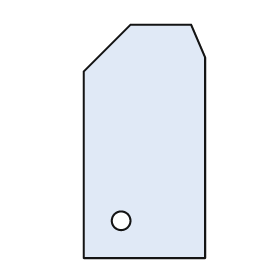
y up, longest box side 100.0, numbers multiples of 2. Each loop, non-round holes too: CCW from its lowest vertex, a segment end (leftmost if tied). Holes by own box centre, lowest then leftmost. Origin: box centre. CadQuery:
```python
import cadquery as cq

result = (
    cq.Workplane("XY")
    .moveTo(-26.0, -50.0)
    .lineTo(26.0, -50.0)
    .lineTo(26.0, 36.0)
    .lineTo(20.0, 50.0)
    .lineTo(-6.0, 50.0)
    .lineTo(-26.0, 30.0)
    .close()
    .moveTo(-10.0, -34.0)
    .circle(4.0)
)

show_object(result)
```